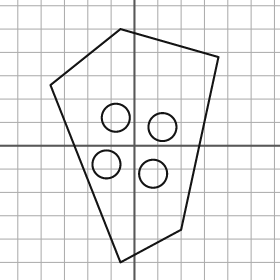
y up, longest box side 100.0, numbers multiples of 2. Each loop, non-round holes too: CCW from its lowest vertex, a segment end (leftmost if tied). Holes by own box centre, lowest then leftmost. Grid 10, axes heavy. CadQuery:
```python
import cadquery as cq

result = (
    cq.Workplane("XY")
    .moveTo(-6.0, -50.0)
    .lineTo(20.0, -36.0)
    .lineTo(36.0, 38.0)
    .lineTo(-6.0, 50.0)
    .lineTo(-36.0, 26.0)
    .close()
    .moveTo(8.0, -12.0)
    .circle(6.0)
    .moveTo(-12.0, -8.0)
    .circle(6.0)
    .moveTo(12.0, 8.0)
    .circle(6.0)
    .moveTo(-8.0, 12.0)
    .circle(6.0)
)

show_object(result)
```